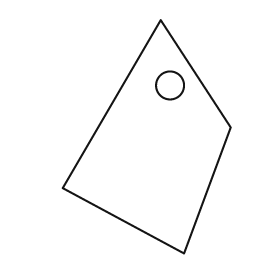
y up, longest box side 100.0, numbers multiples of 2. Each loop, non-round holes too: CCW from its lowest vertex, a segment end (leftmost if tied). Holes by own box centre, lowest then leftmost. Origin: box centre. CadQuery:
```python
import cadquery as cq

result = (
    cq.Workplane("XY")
    .moveTo(16.0, -50.0)
    .lineTo(36.0, 4.0)
    .lineTo(6.0, 50.0)
    .lineTo(-36.0, -22.0)
    .close()
    .moveTo(10.0, 22.0)
    .circle(6.0)
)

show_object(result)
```